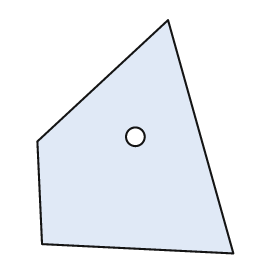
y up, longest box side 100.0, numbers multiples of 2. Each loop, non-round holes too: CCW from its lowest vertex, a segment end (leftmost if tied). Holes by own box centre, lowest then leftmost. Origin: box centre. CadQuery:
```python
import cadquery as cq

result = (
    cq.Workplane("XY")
    .moveTo(42.0, -50.0)
    .lineTo(14.0, 50.0)
    .lineTo(-42.0, -2.0)
    .lineTo(-40.0, -46.0)
    .close()
    .moveTo(0.0, 0.0)
    .circle(4.0)
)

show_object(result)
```